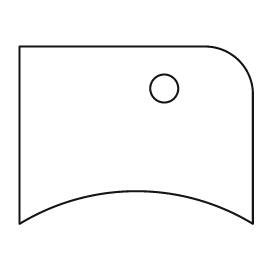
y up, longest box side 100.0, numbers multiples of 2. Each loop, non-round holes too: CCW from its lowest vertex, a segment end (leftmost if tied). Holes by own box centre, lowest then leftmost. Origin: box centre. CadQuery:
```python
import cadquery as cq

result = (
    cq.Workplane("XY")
    .moveTo(-50.0, -38.0)
    .threePointArc((0.0, -24.0), (50.0, -38.0))
    .lineTo(50.0, 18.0)
    .threePointArc((44.0, 32.0), (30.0, 38.0))
    .lineTo(-50.0, 38.0)
    .close()
    .moveTo(12.0, 20.0)
    .circle(6.0)
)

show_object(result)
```